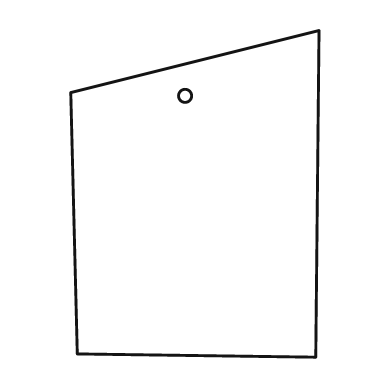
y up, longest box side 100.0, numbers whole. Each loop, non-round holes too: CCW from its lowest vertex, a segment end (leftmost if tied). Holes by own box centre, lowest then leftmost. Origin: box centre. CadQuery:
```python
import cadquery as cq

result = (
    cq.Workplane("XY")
    .moveTo(37.0, -50.0)
    .lineTo(38.0, 50.0)
    .lineTo(-38.0, 31.0)
    .lineTo(-36.0, -49.0)
    .close()
    .moveTo(-3.0, 30.0)
    .circle(2.0)
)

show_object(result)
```